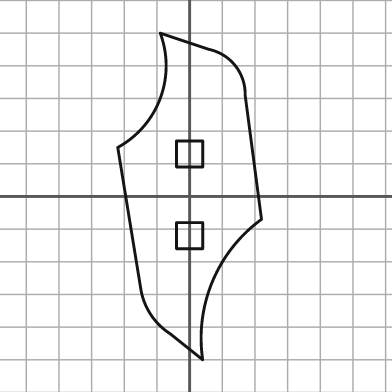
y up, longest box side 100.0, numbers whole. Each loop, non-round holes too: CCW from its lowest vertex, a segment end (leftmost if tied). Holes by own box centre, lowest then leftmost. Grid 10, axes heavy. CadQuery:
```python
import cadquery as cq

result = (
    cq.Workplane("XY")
    .moveTo(4.0, -50.0)
    .threePointArc((7.0, -26.0), (22.0, -7.0))
    .lineTo(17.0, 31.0)
    .threePointArc((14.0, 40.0), (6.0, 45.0))
    .lineTo(-9.0, 50.0)
    .threePointArc((-9.0, 30.0), (-22.0, 15.0))
    .lineTo(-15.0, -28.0)
    .threePointArc((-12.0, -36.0), (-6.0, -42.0))
    .close()
    .moveTo(-4.0, -16.0)
    .lineTo(4.0, -16.0)
    .lineTo(4.0, -8.0)
    .lineTo(-4.0, -8.0)
    .close()
    .moveTo(-4.0, 9.0)
    .lineTo(4.0, 9.0)
    .lineTo(4.0, 17.0)
    .lineTo(-4.0, 17.0)
    .close()
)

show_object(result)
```